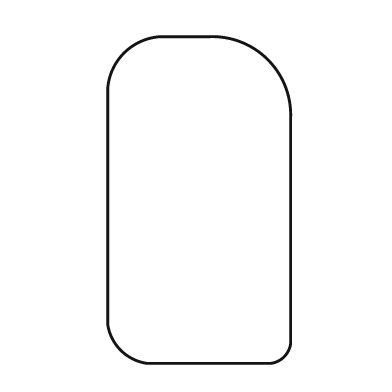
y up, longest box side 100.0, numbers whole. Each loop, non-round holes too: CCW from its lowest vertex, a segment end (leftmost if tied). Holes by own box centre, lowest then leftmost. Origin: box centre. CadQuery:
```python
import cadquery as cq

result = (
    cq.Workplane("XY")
    .moveTo(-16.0, -50.0)
    .lineTo(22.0, -50.0)
    .threePointArc((26.0, -48.0), (28.0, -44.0))
    .lineTo(28.0, 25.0)
    .threePointArc((21.0, 43.0), (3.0, 50.0))
    .lineTo(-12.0, 50.0)
    .threePointArc((-23.0, 45.0), (-28.0, 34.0))
    .lineTo(-28.0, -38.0)
    .threePointArc((-24.0, -46.0), (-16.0, -50.0))
    .close()
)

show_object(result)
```